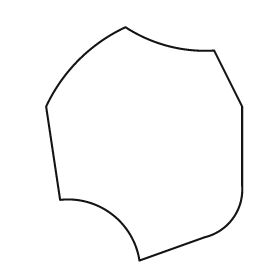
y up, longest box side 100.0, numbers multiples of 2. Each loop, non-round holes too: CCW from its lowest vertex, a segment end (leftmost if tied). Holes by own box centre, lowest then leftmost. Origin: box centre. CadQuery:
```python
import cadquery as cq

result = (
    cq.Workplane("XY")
    .moveTo(-2.0, -50.0)
    .lineTo(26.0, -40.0)
    .threePointArc((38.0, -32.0), (42.0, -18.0))
    .lineTo(42.0, 16.0)
    .lineTo(30.0, 40.0)
    .threePointArc((10.0, 42.0), (-8.0, 50.0))
    .threePointArc((-28.0, 36.0), (-42.0, 16.0))
    .lineTo(-36.0, -24.0)
    .threePointArc((-14.0, -30.0), (-2.0, -50.0))
    .close()
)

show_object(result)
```